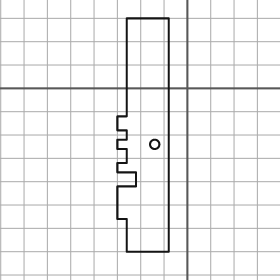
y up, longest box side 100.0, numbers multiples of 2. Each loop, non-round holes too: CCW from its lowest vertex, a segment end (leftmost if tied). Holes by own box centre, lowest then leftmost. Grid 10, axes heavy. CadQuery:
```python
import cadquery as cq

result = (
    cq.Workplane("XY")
    .moveTo(-26.0, -70.0)
    .lineTo(-8.0, -70.0)
    .lineTo(-8.0, 30.0)
    .lineTo(-26.0, 30.0)
    .lineTo(-26.0, -12.0)
    .lineTo(-30.0, -12.0)
    .lineTo(-30.0, -18.0)
    .lineTo(-26.0, -18.0)
    .lineTo(-26.0, -22.0)
    .lineTo(-30.0, -22.0)
    .lineTo(-30.0, -26.0)
    .lineTo(-26.0, -26.0)
    .lineTo(-26.0, -32.0)
    .lineTo(-30.0, -32.0)
    .lineTo(-30.0, -36.0)
    .lineTo(-22.0, -36.0)
    .lineTo(-22.0, -42.0)
    .lineTo(-30.0, -42.0)
    .lineTo(-30.0, -56.0)
    .lineTo(-26.0, -56.0)
    .close()
    .moveTo(-14.0, -24.0)
    .circle(2.0)
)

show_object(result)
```